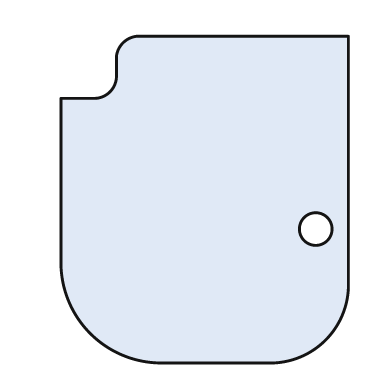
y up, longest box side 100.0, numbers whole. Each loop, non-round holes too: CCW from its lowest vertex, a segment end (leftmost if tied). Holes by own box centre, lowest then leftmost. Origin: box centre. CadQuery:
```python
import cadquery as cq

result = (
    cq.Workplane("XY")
    .moveTo(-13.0, -50.0)
    .lineTo(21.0, -50.0)
    .threePointArc((37.0, -43.0), (44.0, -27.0))
    .lineTo(44.0, 50.0)
    .lineTo(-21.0, 50.0)
    .threePointArc((-25.0, 48.0), (-27.0, 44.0))
    .lineTo(-27.0, 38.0)
    .threePointArc((-29.0, 33.0), (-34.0, 31.0))
    .lineTo(-44.0, 31.0)
    .lineTo(-44.0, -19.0)
    .threePointArc((-35.0, -41.0), (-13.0, -50.0))
    .close()
    .moveTo(34.0, -9.0)
    .circle(5.0)
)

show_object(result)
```